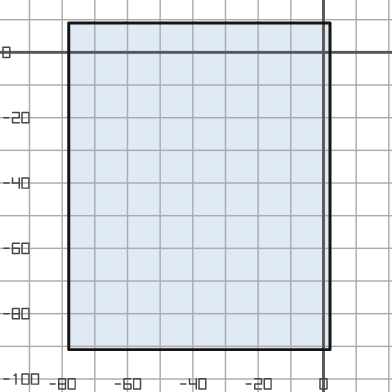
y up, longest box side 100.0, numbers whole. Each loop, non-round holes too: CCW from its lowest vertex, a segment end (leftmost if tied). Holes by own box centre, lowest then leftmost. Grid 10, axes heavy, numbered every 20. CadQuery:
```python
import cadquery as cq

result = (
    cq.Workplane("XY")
    .moveTo(-78.0, -91.0)
    .lineTo(2.0, -91.0)
    .lineTo(2.0, 9.0)
    .lineTo(-78.0, 9.0)
    .close()
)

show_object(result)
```